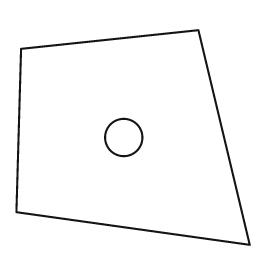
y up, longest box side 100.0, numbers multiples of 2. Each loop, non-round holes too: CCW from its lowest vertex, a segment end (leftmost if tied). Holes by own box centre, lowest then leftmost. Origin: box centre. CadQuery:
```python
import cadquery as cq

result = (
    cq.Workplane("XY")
    .moveTo(50.0, -46.0)
    .lineTo(28.0, 46.0)
    .lineTo(-48.0, 38.0)
    .lineTo(-50.0, -32.0)
    .close()
    .moveTo(-4.0, 0.0)
    .circle(8.0)
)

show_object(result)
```